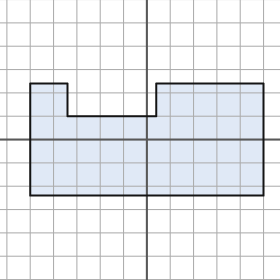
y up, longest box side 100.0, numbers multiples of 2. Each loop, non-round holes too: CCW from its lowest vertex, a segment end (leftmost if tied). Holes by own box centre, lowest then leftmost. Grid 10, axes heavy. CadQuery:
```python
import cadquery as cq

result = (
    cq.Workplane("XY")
    .moveTo(-50.0, -24.0)
    .lineTo(50.0, -24.0)
    .lineTo(50.0, 24.0)
    .lineTo(4.0, 24.0)
    .lineTo(4.0, 10.0)
    .lineTo(-34.0, 10.0)
    .lineTo(-34.0, 24.0)
    .lineTo(-50.0, 24.0)
    .close()
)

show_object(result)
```